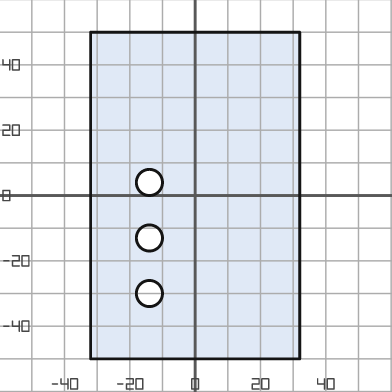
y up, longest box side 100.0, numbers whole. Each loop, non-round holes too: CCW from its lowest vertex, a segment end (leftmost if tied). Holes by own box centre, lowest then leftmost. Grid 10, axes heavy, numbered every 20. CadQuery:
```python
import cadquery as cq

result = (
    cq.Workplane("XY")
    .moveTo(-32.0, -50.0)
    .lineTo(32.0, -50.0)
    .lineTo(32.0, 50.0)
    .lineTo(-32.0, 50.0)
    .close()
    .moveTo(-14.0, -30.0)
    .circle(4.0)
    .moveTo(-14.0, -13.0)
    .circle(4.0)
    .moveTo(-14.0, 4.0)
    .circle(4.0)
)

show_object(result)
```